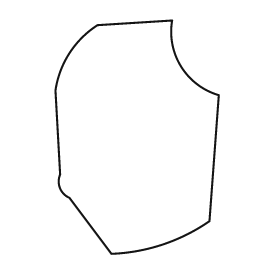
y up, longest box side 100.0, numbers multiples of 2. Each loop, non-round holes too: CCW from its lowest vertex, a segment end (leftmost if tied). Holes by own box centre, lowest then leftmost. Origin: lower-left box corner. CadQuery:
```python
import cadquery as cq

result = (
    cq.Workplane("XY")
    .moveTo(24.0, 0.0)
    .threePointArc((46.0, 4.0), (66.0, 14.0))
    .lineTo(70.0, 68.0)
    .threePointArc((54.0, 80.0), (50.0, 100.0))
    .lineTo(18.0, 98.0)
    .threePointArc((6.0, 86.0), (0.0, 70.0))
    .lineTo(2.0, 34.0)
    .threePointArc((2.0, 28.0), (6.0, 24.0))
    .close()
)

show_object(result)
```